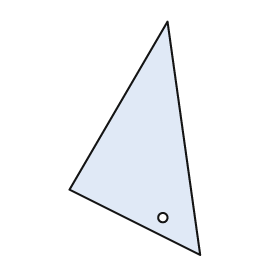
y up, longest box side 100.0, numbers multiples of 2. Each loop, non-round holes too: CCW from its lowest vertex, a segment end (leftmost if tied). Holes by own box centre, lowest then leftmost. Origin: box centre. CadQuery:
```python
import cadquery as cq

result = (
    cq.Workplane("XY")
    .moveTo(28.0, -50.0)
    .lineTo(14.0, 50.0)
    .lineTo(-28.0, -22.0)
    .close()
    .moveTo(12.0, -34.0)
    .circle(2.0)
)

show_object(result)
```